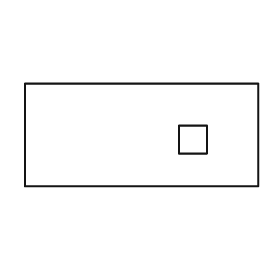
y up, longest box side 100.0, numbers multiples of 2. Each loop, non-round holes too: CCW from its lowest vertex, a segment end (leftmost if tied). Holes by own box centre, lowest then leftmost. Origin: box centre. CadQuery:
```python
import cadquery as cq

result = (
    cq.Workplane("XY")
    .moveTo(-50.0, -22.0)
    .lineTo(50.0, -22.0)
    .lineTo(50.0, 22.0)
    .lineTo(-50.0, 22.0)
    .close()
    .moveTo(16.0, -8.0)
    .lineTo(28.0, -8.0)
    .lineTo(28.0, 4.0)
    .lineTo(16.0, 4.0)
    .close()
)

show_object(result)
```